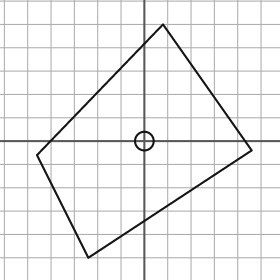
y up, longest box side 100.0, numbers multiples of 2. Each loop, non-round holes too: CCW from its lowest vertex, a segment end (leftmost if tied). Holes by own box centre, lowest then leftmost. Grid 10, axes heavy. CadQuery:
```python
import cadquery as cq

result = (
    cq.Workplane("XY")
    .moveTo(-24.0, -50.0)
    .lineTo(46.0, -4.0)
    .lineTo(8.0, 50.0)
    .lineTo(-46.0, -6.0)
    .close()
    .moveTo(0.0, 0.0)
    .circle(4.0)
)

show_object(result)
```